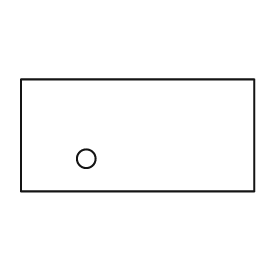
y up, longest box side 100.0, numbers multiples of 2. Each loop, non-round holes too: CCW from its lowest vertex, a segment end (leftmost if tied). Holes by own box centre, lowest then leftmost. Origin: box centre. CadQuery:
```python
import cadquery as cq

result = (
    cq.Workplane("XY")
    .moveTo(-50.0, -24.0)
    .lineTo(50.0, -24.0)
    .lineTo(50.0, 24.0)
    .lineTo(-50.0, 24.0)
    .close()
    .moveTo(-22.0, -10.0)
    .circle(4.0)
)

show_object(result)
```